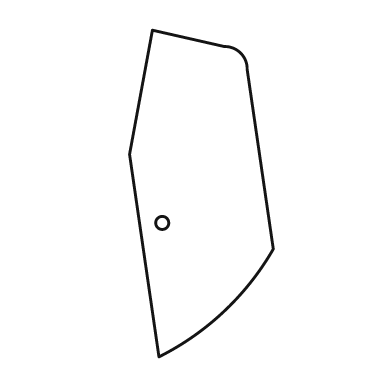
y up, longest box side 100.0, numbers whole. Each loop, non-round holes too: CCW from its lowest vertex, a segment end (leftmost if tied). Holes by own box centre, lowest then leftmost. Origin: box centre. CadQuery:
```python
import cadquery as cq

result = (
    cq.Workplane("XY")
    .moveTo(-13.0, -50.0)
    .threePointArc((7.0, -36.0), (22.0, -17.0))
    .lineTo(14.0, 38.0)
    .threePointArc((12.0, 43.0), (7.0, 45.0))
    .lineTo(-15.0, 50.0)
    .lineTo(-22.0, 12.0)
    .close()
    .moveTo(-12.0, -9.0)
    .circle(2.0)
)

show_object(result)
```